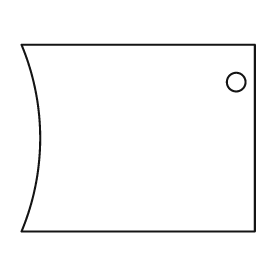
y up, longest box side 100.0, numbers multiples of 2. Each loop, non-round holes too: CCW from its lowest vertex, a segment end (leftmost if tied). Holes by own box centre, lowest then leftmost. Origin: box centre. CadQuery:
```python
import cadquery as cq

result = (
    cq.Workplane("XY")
    .moveTo(-50.0, -40.0)
    .lineTo(50.0, -40.0)
    .lineTo(50.0, 40.0)
    .lineTo(-50.0, 40.0)
    .threePointArc((-42.0, 0.0), (-50.0, -40.0))
    .close()
    .moveTo(42.0, 24.0)
    .circle(4.0)
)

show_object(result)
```